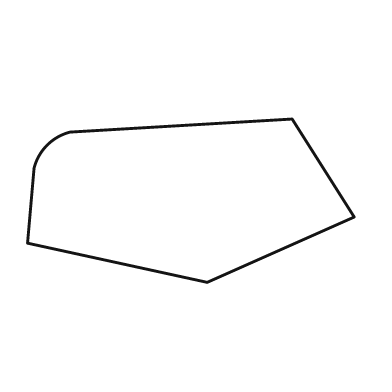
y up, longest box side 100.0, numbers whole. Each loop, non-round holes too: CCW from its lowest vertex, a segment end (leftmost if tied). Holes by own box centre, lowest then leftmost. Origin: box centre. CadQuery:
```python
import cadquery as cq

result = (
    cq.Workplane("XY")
    .moveTo(5.0, -25.0)
    .lineTo(50.0, -5.0)
    .lineTo(31.0, 25.0)
    .lineTo(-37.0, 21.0)
    .threePointArc((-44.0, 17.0), (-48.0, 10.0))
    .lineTo(-50.0, -13.0)
    .close()
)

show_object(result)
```